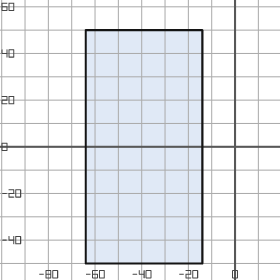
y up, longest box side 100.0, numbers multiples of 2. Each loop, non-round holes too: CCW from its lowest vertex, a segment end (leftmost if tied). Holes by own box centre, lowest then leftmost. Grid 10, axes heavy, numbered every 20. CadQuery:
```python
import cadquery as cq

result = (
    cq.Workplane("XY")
    .moveTo(-64.0, -50.0)
    .lineTo(-14.0, -50.0)
    .lineTo(-14.0, 50.0)
    .lineTo(-64.0, 50.0)
    .close()
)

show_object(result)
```